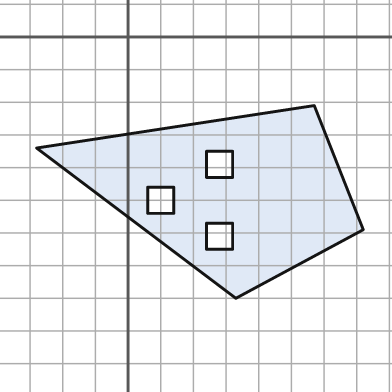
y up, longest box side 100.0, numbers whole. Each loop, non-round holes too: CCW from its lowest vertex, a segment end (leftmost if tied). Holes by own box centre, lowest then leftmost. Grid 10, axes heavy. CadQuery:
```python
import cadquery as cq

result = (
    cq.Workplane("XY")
    .moveTo(33.0, -80.0)
    .lineTo(72.0, -59.0)
    .lineTo(57.0, -21.0)
    .lineTo(-28.0, -34.0)
    .close()
    .moveTo(24.0, -65.0)
    .lineTo(32.0, -65.0)
    .lineTo(32.0, -57.0)
    .lineTo(24.0, -57.0)
    .close()
    .moveTo(6.0, -54.0)
    .lineTo(14.0, -54.0)
    .lineTo(14.0, -46.0)
    .lineTo(6.0, -46.0)
    .close()
    .moveTo(24.0, -43.0)
    .lineTo(32.0, -43.0)
    .lineTo(32.0, -35.0)
    .lineTo(24.0, -35.0)
    .close()
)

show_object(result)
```